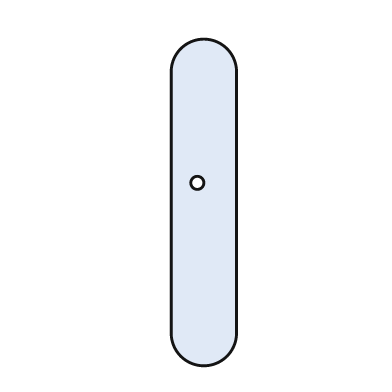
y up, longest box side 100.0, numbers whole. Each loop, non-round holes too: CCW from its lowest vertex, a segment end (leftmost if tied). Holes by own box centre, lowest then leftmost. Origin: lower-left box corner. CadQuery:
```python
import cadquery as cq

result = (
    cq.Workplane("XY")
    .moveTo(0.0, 10.0)
    .threePointArc((10.0, 0.0), (20.0, 10.0))
    .lineTo(20.0, 90.0)
    .threePointArc((10.0, 100.0), (0.0, 90.0))
    .close()
    .moveTo(8.0, 56.0)
    .circle(2.0)
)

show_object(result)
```